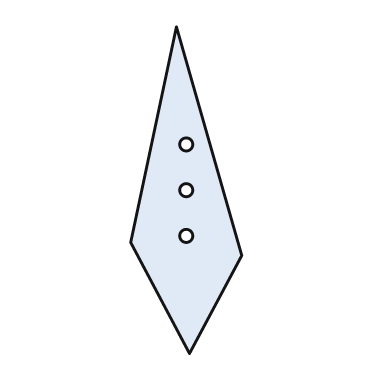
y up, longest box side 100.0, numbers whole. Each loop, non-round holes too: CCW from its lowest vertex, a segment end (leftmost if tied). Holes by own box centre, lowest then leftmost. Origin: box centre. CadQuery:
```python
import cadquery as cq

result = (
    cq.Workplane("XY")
    .moveTo(1.0, -50.0)
    .lineTo(17.0, -20.0)
    .lineTo(-3.0, 50.0)
    .lineTo(-17.0, -16.0)
    .close()
    .moveTo(0.0, -14.0)
    .circle(2.0)
    .moveTo(0.0, 0.0)
    .circle(2.0)
    .moveTo(0.0, 14.0)
    .circle(2.0)
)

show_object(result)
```